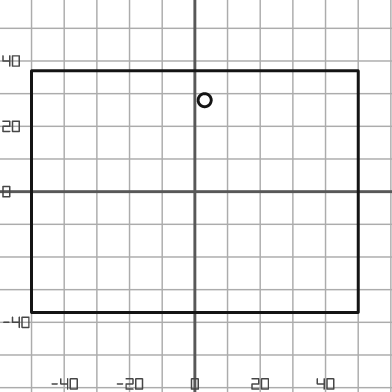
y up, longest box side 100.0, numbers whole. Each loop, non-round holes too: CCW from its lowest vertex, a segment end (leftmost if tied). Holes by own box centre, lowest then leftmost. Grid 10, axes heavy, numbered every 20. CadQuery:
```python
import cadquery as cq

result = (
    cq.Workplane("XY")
    .moveTo(-50.0, -37.0)
    .lineTo(50.0, -37.0)
    .lineTo(50.0, 37.0)
    .lineTo(-50.0, 37.0)
    .close()
    .moveTo(3.0, 28.0)
    .circle(2.0)
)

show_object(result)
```